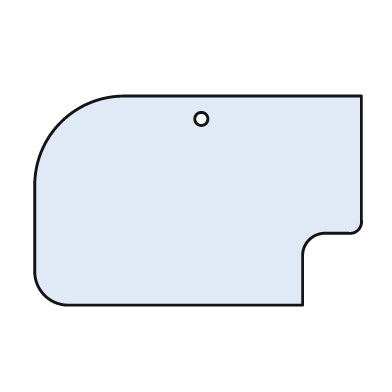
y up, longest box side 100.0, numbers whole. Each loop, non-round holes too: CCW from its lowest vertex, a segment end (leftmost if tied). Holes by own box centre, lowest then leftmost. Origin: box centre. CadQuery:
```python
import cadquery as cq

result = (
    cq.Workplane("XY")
    .moveTo(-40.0, -32.0)
    .lineTo(32.0, -32.0)
    .lineTo(32.0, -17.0)
    .threePointArc((34.0, -12.0), (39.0, -10.0))
    .lineTo(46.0, -10.0)
    .threePointArc((49.0, -9.0), (50.0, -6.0))
    .lineTo(50.0, 32.0)
    .lineTo(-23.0, 32.0)
    .threePointArc((-42.0, 24.0), (-50.0, 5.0))
    .lineTo(-50.0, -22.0)
    .threePointArc((-47.0, -29.0), (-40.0, -32.0))
    .close()
    .moveTo(1.0, 25.0)
    .circle(2.0)
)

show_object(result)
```